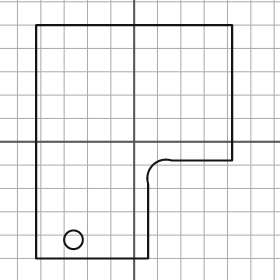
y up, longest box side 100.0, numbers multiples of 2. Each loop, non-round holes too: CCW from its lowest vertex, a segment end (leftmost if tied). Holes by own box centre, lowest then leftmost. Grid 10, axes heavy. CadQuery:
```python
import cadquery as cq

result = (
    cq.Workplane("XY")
    .moveTo(-42.0, -50.0)
    .lineTo(6.0, -50.0)
    .lineTo(6.0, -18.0)
    .threePointArc((8.0, -10.0), (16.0, -8.0))
    .lineTo(42.0, -8.0)
    .lineTo(42.0, 50.0)
    .lineTo(-42.0, 50.0)
    .close()
    .moveTo(-26.0, -42.0)
    .circle(4.0)
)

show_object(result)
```